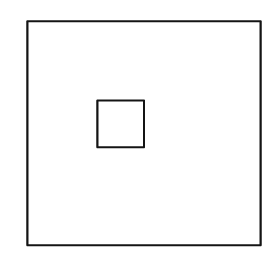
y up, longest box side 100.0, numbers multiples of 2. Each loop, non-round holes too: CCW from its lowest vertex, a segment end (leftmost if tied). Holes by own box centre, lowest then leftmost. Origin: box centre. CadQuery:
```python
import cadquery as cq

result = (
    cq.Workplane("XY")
    .moveTo(-50.0, -48.0)
    .lineTo(50.0, -48.0)
    .lineTo(50.0, 48.0)
    .lineTo(-50.0, 48.0)
    .close()
    .moveTo(-20.0, -6.0)
    .lineTo(0.0, -6.0)
    .lineTo(0.0, 14.0)
    .lineTo(-20.0, 14.0)
    .close()
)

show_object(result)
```